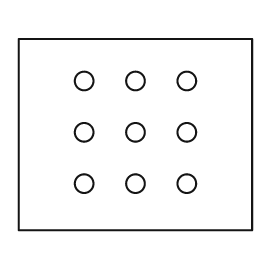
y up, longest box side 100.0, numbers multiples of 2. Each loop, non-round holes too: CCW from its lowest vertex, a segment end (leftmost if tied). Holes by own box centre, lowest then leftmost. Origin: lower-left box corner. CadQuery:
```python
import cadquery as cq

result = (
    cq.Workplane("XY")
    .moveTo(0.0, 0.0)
    .lineTo(100.0, 0.0)
    .lineTo(100.0, 82.0)
    .lineTo(0.0, 82.0)
    .close()
    .moveTo(28.0, 20.0)
    .circle(4.0)
    .moveTo(50.0, 20.0)
    .circle(4.0)
    .moveTo(72.0, 20.0)
    .circle(4.0)
    .moveTo(28.0, 42.0)
    .circle(4.0)
    .moveTo(50.0, 42.0)
    .circle(4.0)
    .moveTo(72.0, 42.0)
    .circle(4.0)
    .moveTo(28.0, 64.0)
    .circle(4.0)
    .moveTo(50.0, 64.0)
    .circle(4.0)
    .moveTo(72.0, 64.0)
    .circle(4.0)
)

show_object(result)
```